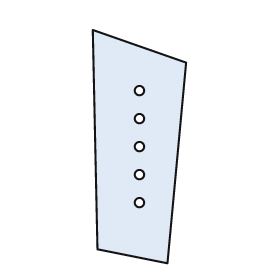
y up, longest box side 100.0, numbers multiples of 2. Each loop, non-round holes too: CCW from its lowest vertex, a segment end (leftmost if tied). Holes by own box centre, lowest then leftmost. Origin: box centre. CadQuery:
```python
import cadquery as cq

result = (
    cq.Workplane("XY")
    .moveTo(12.0, -50.0)
    .lineTo(20.0, 36.0)
    .lineTo(-20.0, 50.0)
    .lineTo(-18.0, -44.0)
    .close()
    .moveTo(0.0, -24.0)
    .circle(2.0)
    .moveTo(0.0, -12.0)
    .circle(2.0)
    .moveTo(0.0, 0.0)
    .circle(2.0)
    .moveTo(0.0, 12.0)
    .circle(2.0)
    .moveTo(0.0, 24.0)
    .circle(2.0)
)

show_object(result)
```